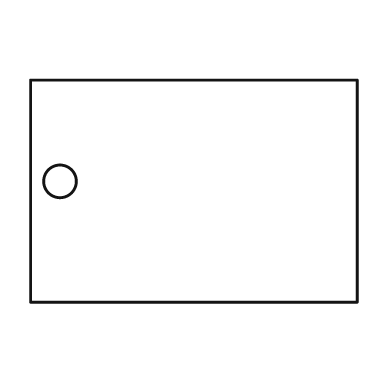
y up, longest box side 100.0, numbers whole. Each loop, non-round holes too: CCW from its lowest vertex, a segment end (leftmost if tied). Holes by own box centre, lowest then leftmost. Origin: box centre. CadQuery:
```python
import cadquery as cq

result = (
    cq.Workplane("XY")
    .moveTo(-50.0, -34.0)
    .lineTo(50.0, -34.0)
    .lineTo(50.0, 34.0)
    .lineTo(-50.0, 34.0)
    .close()
    .moveTo(-41.0, 3.0)
    .circle(5.0)
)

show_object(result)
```